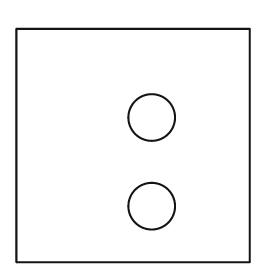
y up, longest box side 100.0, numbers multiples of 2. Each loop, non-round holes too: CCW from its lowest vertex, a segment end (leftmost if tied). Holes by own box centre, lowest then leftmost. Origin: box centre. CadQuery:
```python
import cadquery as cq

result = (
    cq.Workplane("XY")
    .moveTo(-50.0, -50.0)
    .lineTo(50.0, -50.0)
    .lineTo(50.0, 50.0)
    .lineTo(-50.0, 50.0)
    .close()
    .moveTo(8.0, -26.0)
    .circle(10.0)
    .moveTo(8.0, 12.0)
    .circle(10.0)
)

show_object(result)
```